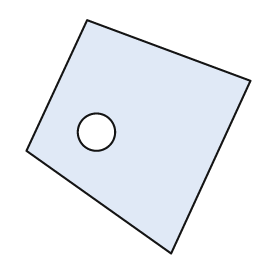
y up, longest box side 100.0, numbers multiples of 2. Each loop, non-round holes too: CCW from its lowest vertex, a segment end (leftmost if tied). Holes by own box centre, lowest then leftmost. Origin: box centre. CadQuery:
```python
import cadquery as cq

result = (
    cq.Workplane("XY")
    .moveTo(14.0, -50.0)
    .lineTo(48.0, 24.0)
    .lineTo(-22.0, 50.0)
    .lineTo(-48.0, -6.0)
    .close()
    .moveTo(-18.0, 2.0)
    .circle(8.0)
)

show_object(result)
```